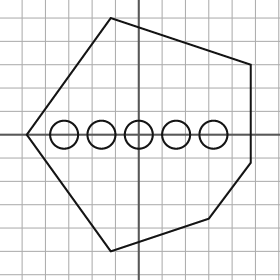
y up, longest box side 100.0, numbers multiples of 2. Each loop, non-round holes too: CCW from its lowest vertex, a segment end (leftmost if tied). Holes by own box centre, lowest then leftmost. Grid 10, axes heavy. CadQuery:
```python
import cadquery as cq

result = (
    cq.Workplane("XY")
    .moveTo(-12.0, -50.0)
    .lineTo(30.0, -36.0)
    .lineTo(48.0, -12.0)
    .lineTo(48.0, 30.0)
    .lineTo(-12.0, 50.0)
    .lineTo(-48.0, 0.0)
    .close()
    .moveTo(-32.0, 0.0)
    .circle(6.0)
    .moveTo(-16.0, 0.0)
    .circle(6.0)
    .moveTo(0.0, 0.0)
    .circle(6.0)
    .moveTo(16.0, 0.0)
    .circle(6.0)
    .moveTo(32.0, 0.0)
    .circle(6.0)
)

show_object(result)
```